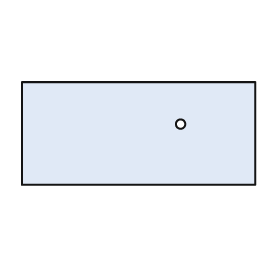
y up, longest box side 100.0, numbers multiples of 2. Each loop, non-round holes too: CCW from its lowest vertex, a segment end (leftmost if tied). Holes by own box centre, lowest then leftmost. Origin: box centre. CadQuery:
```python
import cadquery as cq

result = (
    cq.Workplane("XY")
    .moveTo(-50.0, -22.0)
    .lineTo(50.0, -22.0)
    .lineTo(50.0, 22.0)
    .lineTo(-50.0, 22.0)
    .close()
    .moveTo(18.0, 4.0)
    .circle(2.0)
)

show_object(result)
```